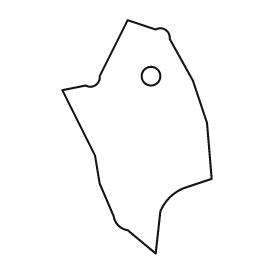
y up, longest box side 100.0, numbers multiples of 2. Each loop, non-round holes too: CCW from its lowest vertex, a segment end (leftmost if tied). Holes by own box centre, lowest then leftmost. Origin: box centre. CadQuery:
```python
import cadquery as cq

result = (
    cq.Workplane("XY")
    .moveTo(8.0, -50.0)
    .lineTo(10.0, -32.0)
    .threePointArc((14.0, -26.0), (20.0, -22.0))
    .lineTo(32.0, -18.0)
    .lineTo(30.0, 6.0)
    .lineTo(24.0, 24.0)
    .lineTo(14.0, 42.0)
    .threePointArc((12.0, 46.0), (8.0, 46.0))
    .lineTo(-4.0, 50.0)
    .lineTo(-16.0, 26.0)
    .threePointArc((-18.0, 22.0), (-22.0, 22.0))
    .lineTo(-32.0, 20.0)
    .lineTo(-18.0, -8.0)
    .lineTo(-16.0, -20.0)
    .lineTo(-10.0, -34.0)
    .threePointArc((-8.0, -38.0), (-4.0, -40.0))
    .close()
    .moveTo(6.0, 26.0)
    .circle(4.0)
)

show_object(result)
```